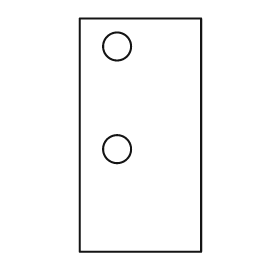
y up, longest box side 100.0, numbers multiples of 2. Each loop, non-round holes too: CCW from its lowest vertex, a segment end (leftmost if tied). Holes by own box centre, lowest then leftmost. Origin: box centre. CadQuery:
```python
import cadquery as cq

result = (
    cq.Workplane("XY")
    .moveTo(-26.0, -50.0)
    .lineTo(26.0, -50.0)
    .lineTo(26.0, 50.0)
    .lineTo(-26.0, 50.0)
    .close()
    .moveTo(-10.0, -6.0)
    .circle(6.0)
    .moveTo(-10.0, 38.0)
    .circle(6.0)
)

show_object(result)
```